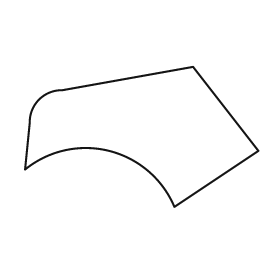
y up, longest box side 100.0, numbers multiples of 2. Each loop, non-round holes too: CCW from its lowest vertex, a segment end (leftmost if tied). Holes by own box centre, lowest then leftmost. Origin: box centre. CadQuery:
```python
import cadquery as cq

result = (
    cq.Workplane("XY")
    .moveTo(14.0, -30.0)
    .lineTo(50.0, -6.0)
    .lineTo(22.0, 30.0)
    .lineTo(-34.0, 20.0)
    .threePointArc((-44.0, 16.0), (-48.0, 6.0))
    .lineTo(-50.0, -14.0)
    .threePointArc((-14.0, -6.0), (14.0, -30.0))
    .close()
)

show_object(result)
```